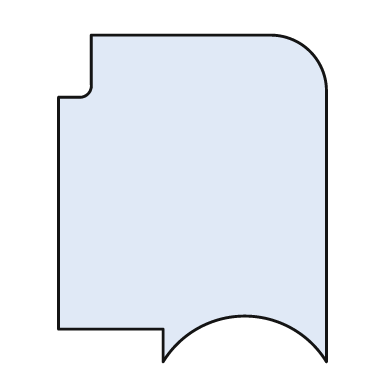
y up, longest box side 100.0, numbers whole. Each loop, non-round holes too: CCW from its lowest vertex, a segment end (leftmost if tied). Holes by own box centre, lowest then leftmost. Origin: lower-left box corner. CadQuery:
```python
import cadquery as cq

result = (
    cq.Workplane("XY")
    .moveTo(32.0, 0.0)
    .threePointArc((57.0, 14.0), (82.0, 0.0))
    .lineTo(82.0, 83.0)
    .threePointArc((77.0, 95.0), (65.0, 100.0))
    .lineTo(10.0, 100.0)
    .lineTo(10.0, 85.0)
    .threePointArc((9.0, 82.0), (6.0, 81.0))
    .lineTo(0.0, 81.0)
    .lineTo(0.0, 10.0)
    .lineTo(32.0, 10.0)
    .close()
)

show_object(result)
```